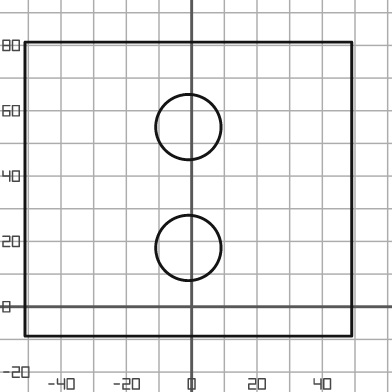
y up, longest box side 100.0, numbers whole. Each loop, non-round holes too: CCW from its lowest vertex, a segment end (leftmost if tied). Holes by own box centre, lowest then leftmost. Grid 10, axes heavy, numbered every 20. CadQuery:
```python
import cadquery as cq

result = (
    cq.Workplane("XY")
    .moveTo(-51.0, -9.0)
    .lineTo(49.0, -9.0)
    .lineTo(49.0, 81.0)
    .lineTo(-51.0, 81.0)
    .close()
    .moveTo(-1.0, 18.0)
    .circle(10.0)
    .moveTo(-1.0, 55.0)
    .circle(10.0)
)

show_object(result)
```